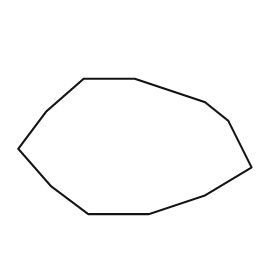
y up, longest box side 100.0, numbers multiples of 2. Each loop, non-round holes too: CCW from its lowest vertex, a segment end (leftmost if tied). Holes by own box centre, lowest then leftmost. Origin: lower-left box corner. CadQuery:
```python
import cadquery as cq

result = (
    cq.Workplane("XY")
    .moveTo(30.0, 0.0)
    .lineTo(56.0, 0.0)
    .lineTo(80.0, 8.0)
    .lineTo(100.0, 20.0)
    .lineTo(90.0, 40.0)
    .lineTo(80.0, 48.0)
    .lineTo(50.0, 58.0)
    .lineTo(28.0, 58.0)
    .lineTo(12.0, 44.0)
    .lineTo(0.0, 28.0)
    .lineTo(14.0, 12.0)
    .close()
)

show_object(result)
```